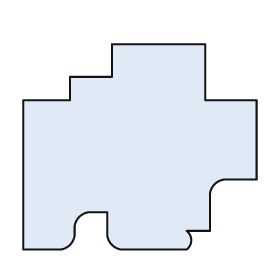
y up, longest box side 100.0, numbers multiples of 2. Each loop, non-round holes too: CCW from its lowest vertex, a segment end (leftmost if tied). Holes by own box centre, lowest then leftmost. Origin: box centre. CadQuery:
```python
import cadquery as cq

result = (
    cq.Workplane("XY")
    .moveTo(-50.0, -44.0)
    .lineTo(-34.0, -44.0)
    .threePointArc((-30.0, -42.0), (-28.0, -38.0))
    .lineTo(-28.0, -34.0)
    .threePointArc((-26.0, -30.0), (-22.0, -28.0))
    .lineTo(-14.0, -28.0)
    .lineTo(-14.0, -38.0)
    .threePointArc((-12.0, -42.0), (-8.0, -44.0))
    .lineTo(20.0, -44.0)
    .threePointArc((22.0, -40.0), (20.0, -36.0))
    .lineTo(30.0, -36.0)
    .lineTo(30.0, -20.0)
    .threePointArc((32.0, -16.0), (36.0, -14.0))
    .lineTo(50.0, -14.0)
    .lineTo(50.0, 20.0)
    .lineTo(28.0, 20.0)
    .lineTo(28.0, 44.0)
    .lineTo(-12.0, 44.0)
    .lineTo(-12.0, 30.0)
    .lineTo(-30.0, 30.0)
    .lineTo(-30.0, 20.0)
    .lineTo(-50.0, 20.0)
    .close()
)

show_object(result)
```